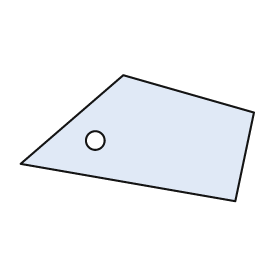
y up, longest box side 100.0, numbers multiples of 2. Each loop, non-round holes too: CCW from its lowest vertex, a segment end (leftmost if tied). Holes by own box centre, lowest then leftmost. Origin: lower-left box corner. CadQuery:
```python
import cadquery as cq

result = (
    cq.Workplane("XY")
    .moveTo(92.0, 0.0)
    .lineTo(100.0, 38.0)
    .lineTo(44.0, 54.0)
    .lineTo(0.0, 16.0)
    .close()
    .moveTo(32.0, 26.0)
    .circle(4.0)
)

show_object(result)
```